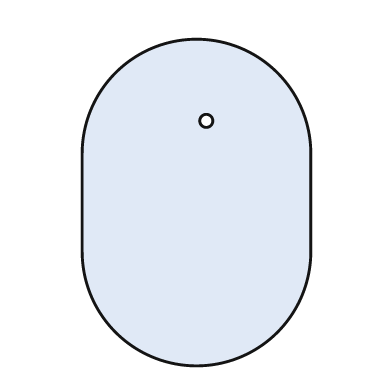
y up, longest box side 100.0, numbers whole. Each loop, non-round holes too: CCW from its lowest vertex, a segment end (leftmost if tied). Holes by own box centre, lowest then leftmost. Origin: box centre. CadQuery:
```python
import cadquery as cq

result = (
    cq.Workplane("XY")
    .moveTo(-35.0, -15.0)
    .threePointArc((0.0, -50.0), (35.0, -15.0))
    .lineTo(35.0, 15.0)
    .threePointArc((0.0, 50.0), (-35.0, 15.0))
    .close()
    .moveTo(3.0, 25.0)
    .circle(2.0)
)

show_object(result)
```